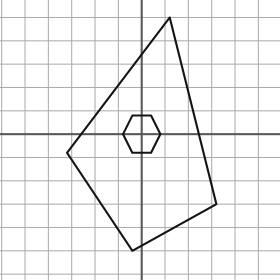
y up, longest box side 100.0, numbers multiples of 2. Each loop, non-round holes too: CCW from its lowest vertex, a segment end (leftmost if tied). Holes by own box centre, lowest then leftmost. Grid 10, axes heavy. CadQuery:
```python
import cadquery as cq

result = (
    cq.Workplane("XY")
    .moveTo(-4.0, -50.0)
    .lineTo(32.0, -30.0)
    .lineTo(12.0, 50.0)
    .lineTo(-32.0, -8.0)
    .close()
    .moveTo(-4.0, -8.0)
    .lineTo(4.0, -8.0)
    .lineTo(8.0, 0.0)
    .lineTo(4.0, 8.0)
    .lineTo(-4.0, 8.0)
    .lineTo(-8.0, 0.0)
    .close()
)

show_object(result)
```